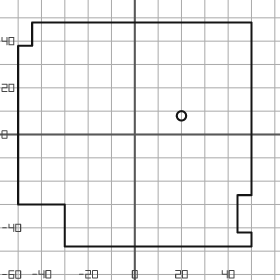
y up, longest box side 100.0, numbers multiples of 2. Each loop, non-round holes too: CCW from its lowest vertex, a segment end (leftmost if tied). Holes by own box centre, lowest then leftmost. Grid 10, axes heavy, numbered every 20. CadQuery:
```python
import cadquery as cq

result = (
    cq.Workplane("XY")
    .moveTo(-30.0, -48.0)
    .lineTo(50.0, -48.0)
    .lineTo(50.0, -42.0)
    .lineTo(44.0, -42.0)
    .lineTo(44.0, -26.0)
    .lineTo(50.0, -26.0)
    .lineTo(50.0, 48.0)
    .lineTo(-44.0, 48.0)
    .lineTo(-44.0, 38.0)
    .lineTo(-50.0, 38.0)
    .lineTo(-50.0, -30.0)
    .lineTo(-30.0, -30.0)
    .close()
    .moveTo(20.0, 8.0)
    .circle(2.0)
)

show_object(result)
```